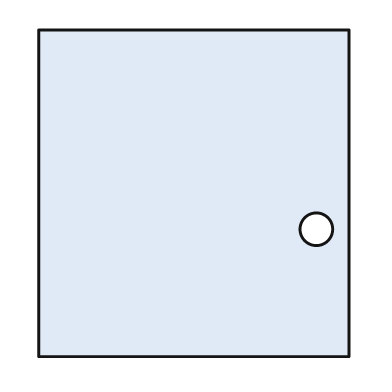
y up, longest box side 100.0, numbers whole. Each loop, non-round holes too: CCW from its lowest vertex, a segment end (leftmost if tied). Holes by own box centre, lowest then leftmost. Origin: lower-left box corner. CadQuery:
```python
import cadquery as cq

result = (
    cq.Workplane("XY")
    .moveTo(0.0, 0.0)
    .lineTo(95.0, 0.0)
    .lineTo(95.0, 100.0)
    .lineTo(0.0, 100.0)
    .close()
    .moveTo(85.0, 39.0)
    .circle(5.0)
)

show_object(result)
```